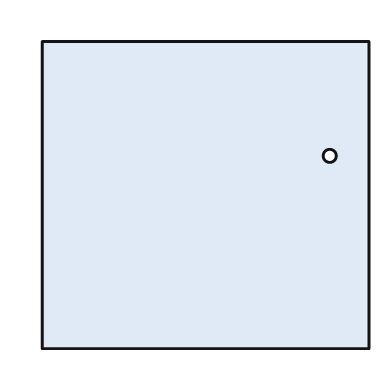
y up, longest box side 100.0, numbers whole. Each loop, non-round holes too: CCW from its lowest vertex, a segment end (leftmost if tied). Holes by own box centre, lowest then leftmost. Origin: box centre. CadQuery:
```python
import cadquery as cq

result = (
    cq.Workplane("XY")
    .moveTo(-50.0, -47.0)
    .lineTo(50.0, -47.0)
    .lineTo(50.0, 47.0)
    .lineTo(-50.0, 47.0)
    .close()
    .moveTo(38.0, 12.0)
    .circle(2.0)
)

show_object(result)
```